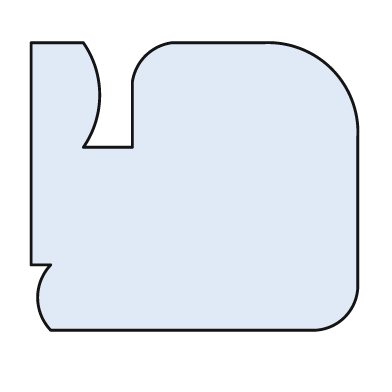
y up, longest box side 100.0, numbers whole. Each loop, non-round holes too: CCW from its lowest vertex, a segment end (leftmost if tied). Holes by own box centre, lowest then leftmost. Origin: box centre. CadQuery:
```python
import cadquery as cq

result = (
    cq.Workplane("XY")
    .moveTo(-44.0, -44.0)
    .lineTo(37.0, -44.0)
    .threePointArc((46.0, -40.0), (50.0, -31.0))
    .lineTo(50.0, 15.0)
    .threePointArc((42.0, 36.0), (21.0, 44.0))
    .lineTo(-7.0, 44.0)
    .threePointArc((-15.0, 40.0), (-19.0, 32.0))
    .lineTo(-19.0, 12.0)
    .lineTo(-34.0, 12.0)
    .threePointArc((-29.0, 28.0), (-34.0, 44.0))
    .lineTo(-50.0, 44.0)
    .lineTo(-50.0, -24.0)
    .lineTo(-44.0, -24.0)
    .threePointArc((-48.0, -34.0), (-44.0, -44.0))
    .close()
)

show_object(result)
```